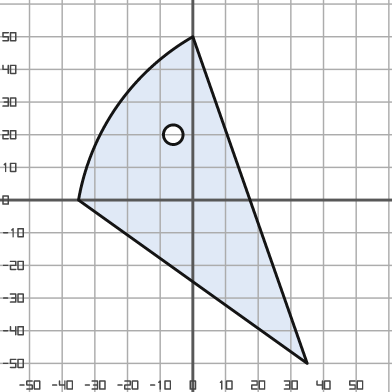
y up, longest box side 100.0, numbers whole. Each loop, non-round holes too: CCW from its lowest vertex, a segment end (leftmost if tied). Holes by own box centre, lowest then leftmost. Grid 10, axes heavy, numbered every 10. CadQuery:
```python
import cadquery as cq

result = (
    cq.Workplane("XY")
    .moveTo(35.0, -50.0)
    .lineTo(0.0, 50.0)
    .threePointArc((-23.0, 29.0), (-35.0, 0.0))
    .close()
    .moveTo(-6.0, 20.0)
    .circle(3.0)
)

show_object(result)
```